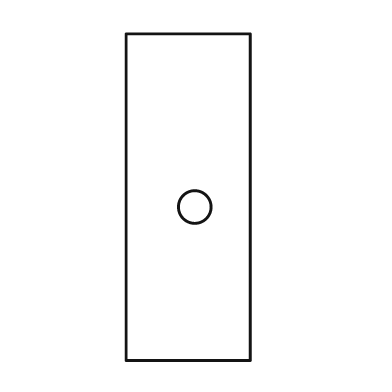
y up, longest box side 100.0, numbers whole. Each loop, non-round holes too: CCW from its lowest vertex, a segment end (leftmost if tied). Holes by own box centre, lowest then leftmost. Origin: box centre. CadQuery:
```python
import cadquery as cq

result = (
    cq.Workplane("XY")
    .moveTo(-19.0, -50.0)
    .lineTo(19.0, -50.0)
    .lineTo(19.0, 50.0)
    .lineTo(-19.0, 50.0)
    .close()
    .moveTo(2.0, -3.0)
    .circle(5.0)
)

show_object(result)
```